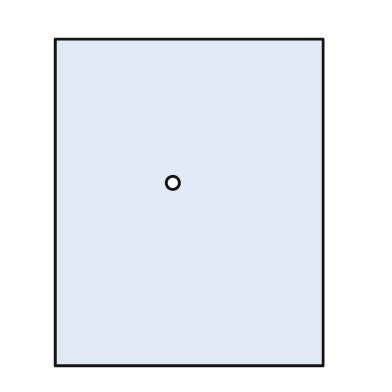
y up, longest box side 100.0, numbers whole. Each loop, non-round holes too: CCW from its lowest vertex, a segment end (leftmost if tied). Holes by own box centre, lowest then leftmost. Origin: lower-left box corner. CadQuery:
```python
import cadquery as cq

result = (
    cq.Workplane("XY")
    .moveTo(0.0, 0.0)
    .lineTo(82.0, 0.0)
    .lineTo(82.0, 100.0)
    .lineTo(0.0, 100.0)
    .close()
    .moveTo(36.0, 56.0)
    .circle(2.0)
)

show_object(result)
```